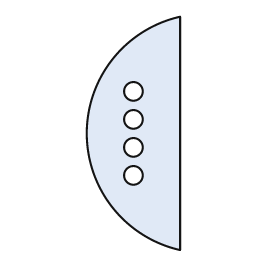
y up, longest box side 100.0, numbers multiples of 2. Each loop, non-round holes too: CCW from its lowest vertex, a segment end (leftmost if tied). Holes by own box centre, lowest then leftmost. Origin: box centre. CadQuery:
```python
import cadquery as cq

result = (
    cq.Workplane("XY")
    .moveTo(20.0, -50.0)
    .lineTo(20.0, 50.0)
    .threePointArc((-20.0, 0.0), (20.0, -50.0))
    .close()
    .moveTo(0.0, -18.0)
    .circle(4.0)
    .moveTo(0.0, -6.0)
    .circle(4.0)
    .moveTo(0.0, 6.0)
    .circle(4.0)
    .moveTo(0.0, 18.0)
    .circle(4.0)
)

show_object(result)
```